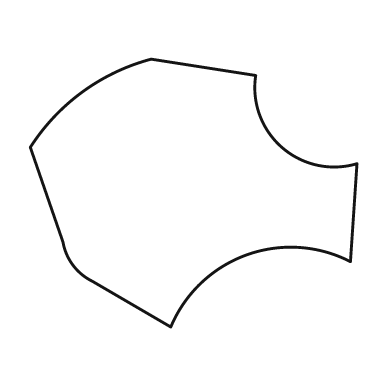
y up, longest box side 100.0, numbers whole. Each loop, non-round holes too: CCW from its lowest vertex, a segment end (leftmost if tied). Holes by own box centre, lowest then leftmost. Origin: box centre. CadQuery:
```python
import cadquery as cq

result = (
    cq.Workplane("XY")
    .moveTo(-7.0, -41.0)
    .threePointArc((16.0, -19.0), (48.0, -21.0))
    .lineTo(50.0, 9.0)
    .threePointArc((27.0, 14.0), (19.0, 36.0))
    .lineTo(-13.0, 41.0)
    .threePointArc((-34.0, 31.0), (-50.0, 14.0))
    .lineTo(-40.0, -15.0)
    .threePointArc((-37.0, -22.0), (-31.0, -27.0))
    .close()
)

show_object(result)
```